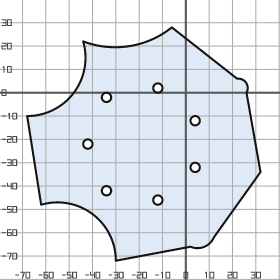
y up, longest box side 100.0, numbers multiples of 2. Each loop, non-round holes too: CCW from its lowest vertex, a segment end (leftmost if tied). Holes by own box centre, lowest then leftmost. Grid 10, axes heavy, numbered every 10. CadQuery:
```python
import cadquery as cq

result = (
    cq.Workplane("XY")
    .moveTo(-30.0, -72.0)
    .lineTo(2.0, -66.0)
    .threePointArc((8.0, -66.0), (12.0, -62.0))
    .lineTo(32.0, -34.0)
    .lineTo(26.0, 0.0)
    .threePointArc((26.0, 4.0), (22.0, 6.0))
    .lineTo(-6.0, 28.0)
    .threePointArc((-24.0, 20.0), (-44.0, 22.0))
    .threePointArc((-48.0, 0.0), (-68.0, -10.0))
    .lineTo(-62.0, -48.0)
    .threePointArc((-40.0, -52.0), (-30.0, -72.0))
    .close()
    .moveTo(-12.0, -46.0)
    .circle(2.0)
    .moveTo(-34.0, -42.0)
    .circle(2.0)
    .moveTo(4.0, -32.0)
    .circle(2.0)
    .moveTo(-42.0, -22.0)
    .circle(2.0)
    .moveTo(4.0, -12.0)
    .circle(2.0)
    .moveTo(-34.0, -2.0)
    .circle(2.0)
    .moveTo(-12.0, 2.0)
    .circle(2.0)
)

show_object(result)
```